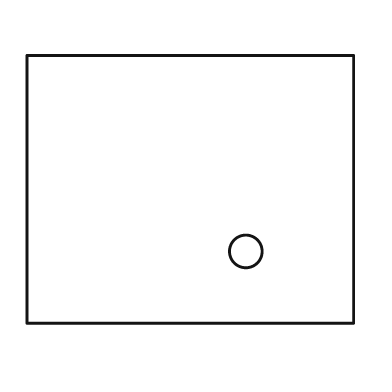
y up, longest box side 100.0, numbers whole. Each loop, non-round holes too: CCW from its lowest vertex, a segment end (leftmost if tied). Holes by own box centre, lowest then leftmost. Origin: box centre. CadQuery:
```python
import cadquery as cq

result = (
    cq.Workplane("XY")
    .moveTo(-50.0, -41.0)
    .lineTo(50.0, -41.0)
    .lineTo(50.0, 41.0)
    .lineTo(-50.0, 41.0)
    .close()
    .moveTo(17.0, -19.0)
    .circle(5.0)
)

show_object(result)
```